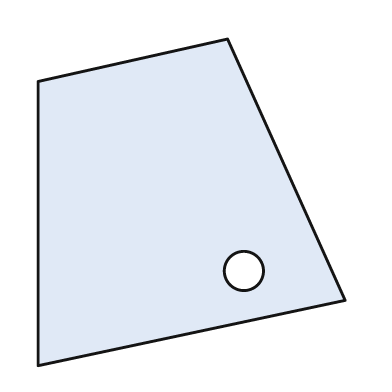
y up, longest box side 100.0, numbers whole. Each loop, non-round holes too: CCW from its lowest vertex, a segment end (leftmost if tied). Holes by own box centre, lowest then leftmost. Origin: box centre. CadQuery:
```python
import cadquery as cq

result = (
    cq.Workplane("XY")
    .moveTo(-47.0, -50.0)
    .lineTo(47.0, -30.0)
    .lineTo(11.0, 50.0)
    .lineTo(-47.0, 37.0)
    .close()
    .moveTo(16.0, -21.0)
    .circle(6.0)
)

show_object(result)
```